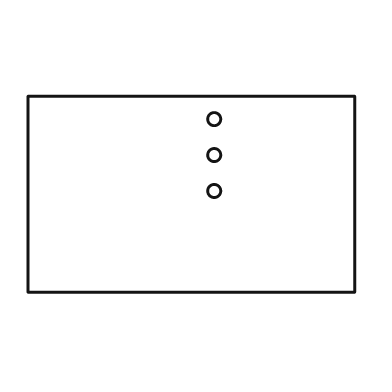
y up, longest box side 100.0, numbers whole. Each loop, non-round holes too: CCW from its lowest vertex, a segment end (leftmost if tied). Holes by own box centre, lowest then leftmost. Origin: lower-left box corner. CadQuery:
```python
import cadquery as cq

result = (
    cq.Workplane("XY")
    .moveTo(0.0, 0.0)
    .lineTo(100.0, 0.0)
    .lineTo(100.0, 60.0)
    .lineTo(0.0, 60.0)
    .close()
    .moveTo(57.0, 31.0)
    .circle(2.0)
    .moveTo(57.0, 42.0)
    .circle(2.0)
    .moveTo(57.0, 53.0)
    .circle(2.0)
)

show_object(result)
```